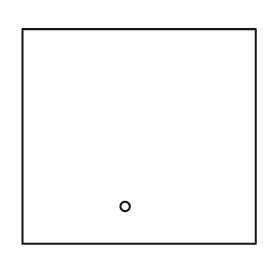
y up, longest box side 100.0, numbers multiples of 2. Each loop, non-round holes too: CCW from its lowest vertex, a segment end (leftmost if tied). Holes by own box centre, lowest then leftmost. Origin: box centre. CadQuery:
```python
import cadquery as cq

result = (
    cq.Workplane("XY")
    .moveTo(-50.0, -46.0)
    .lineTo(50.0, -46.0)
    .lineTo(50.0, 46.0)
    .lineTo(-50.0, 46.0)
    .close()
    .moveTo(-6.0, -30.0)
    .circle(2.0)
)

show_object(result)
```